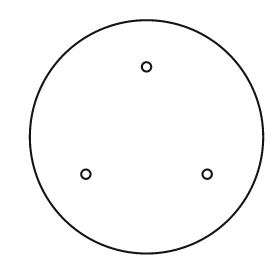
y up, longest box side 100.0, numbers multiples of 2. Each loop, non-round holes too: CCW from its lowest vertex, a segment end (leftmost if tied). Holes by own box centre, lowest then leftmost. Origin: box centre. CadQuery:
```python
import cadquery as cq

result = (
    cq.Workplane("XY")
    .moveTo(0.0, 0.0)
    .circle(50.0)
    .moveTo(-26.0, -16.0)
    .circle(2.0)
    .moveTo(26.0, -16.0)
    .circle(2.0)
    .moveTo(0.0, 30.0)
    .circle(2.0)
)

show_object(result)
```